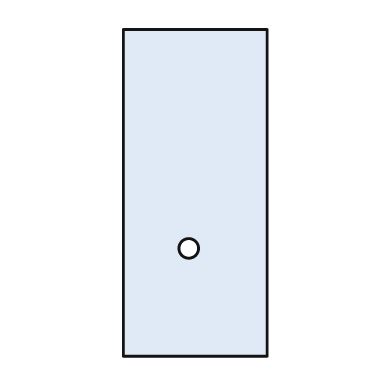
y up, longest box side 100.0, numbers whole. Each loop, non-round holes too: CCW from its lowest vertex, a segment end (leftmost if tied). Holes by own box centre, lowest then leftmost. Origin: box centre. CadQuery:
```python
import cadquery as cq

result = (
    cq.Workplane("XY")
    .moveTo(-22.0, -50.0)
    .lineTo(22.0, -50.0)
    .lineTo(22.0, 50.0)
    .lineTo(-22.0, 50.0)
    .close()
    .moveTo(-2.0, -17.0)
    .circle(3.0)
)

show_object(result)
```